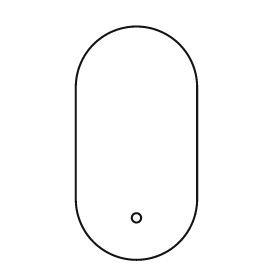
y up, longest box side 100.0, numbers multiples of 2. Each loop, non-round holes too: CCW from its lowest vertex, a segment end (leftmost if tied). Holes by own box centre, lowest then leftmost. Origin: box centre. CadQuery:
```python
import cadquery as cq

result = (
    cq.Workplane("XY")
    .moveTo(-26.0, -24.0)
    .threePointArc((0.0, -50.0), (26.0, -24.0))
    .lineTo(26.0, 24.0)
    .threePointArc((0.0, 50.0), (-26.0, 24.0))
    .close()
    .moveTo(0.0, -32.0)
    .circle(2.0)
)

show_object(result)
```